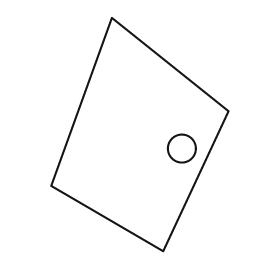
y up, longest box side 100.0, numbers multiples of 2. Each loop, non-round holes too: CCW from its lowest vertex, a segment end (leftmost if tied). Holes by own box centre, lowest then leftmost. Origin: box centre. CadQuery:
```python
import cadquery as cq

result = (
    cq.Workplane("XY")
    .moveTo(10.0, -50.0)
    .lineTo(38.0, 10.0)
    .lineTo(-12.0, 50.0)
    .lineTo(-38.0, -22.0)
    .close()
    .moveTo(18.0, -6.0)
    .circle(6.0)
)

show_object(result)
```